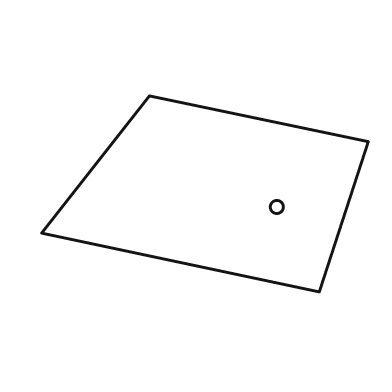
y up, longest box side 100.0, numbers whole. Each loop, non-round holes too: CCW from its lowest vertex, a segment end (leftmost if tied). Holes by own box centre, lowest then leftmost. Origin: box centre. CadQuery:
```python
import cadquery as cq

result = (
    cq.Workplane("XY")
    .moveTo(35.0, -30.0)
    .lineTo(50.0, 16.0)
    .lineTo(-17.0, 30.0)
    .lineTo(-50.0, -12.0)
    .close()
    .moveTo(22.0, -4.0)
    .circle(2.0)
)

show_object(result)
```